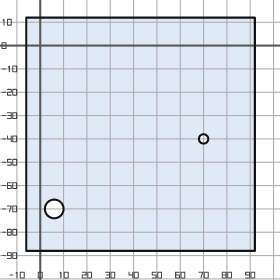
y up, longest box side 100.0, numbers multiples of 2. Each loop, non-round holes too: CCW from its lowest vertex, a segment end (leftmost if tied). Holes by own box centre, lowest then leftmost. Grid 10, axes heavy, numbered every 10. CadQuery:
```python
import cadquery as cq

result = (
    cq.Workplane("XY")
    .moveTo(-6.0, -88.0)
    .lineTo(92.0, -88.0)
    .lineTo(92.0, 12.0)
    .lineTo(-6.0, 12.0)
    .close()
    .moveTo(6.0, -70.0)
    .circle(4.0)
    .moveTo(70.0, -40.0)
    .circle(2.0)
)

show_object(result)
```